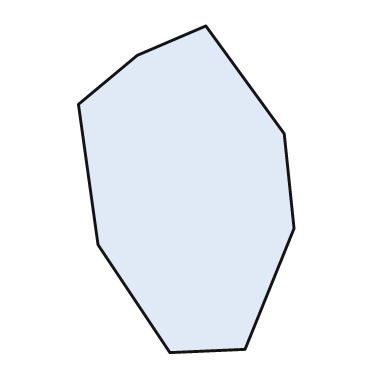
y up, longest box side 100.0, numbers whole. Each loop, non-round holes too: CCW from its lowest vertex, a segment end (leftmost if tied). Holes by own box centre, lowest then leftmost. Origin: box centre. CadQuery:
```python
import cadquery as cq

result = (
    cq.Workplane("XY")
    .moveTo(-5.0, -50.0)
    .lineTo(18.0, -49.0)
    .lineTo(33.0, -12.0)
    .lineTo(30.0, 17.0)
    .lineTo(6.0, 50.0)
    .lineTo(-15.0, 41.0)
    .lineTo(-33.0, 26.0)
    .lineTo(-27.0, -17.0)
    .close()
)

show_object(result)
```